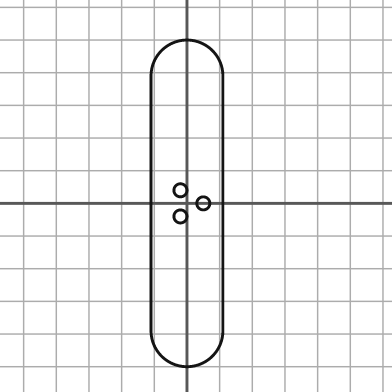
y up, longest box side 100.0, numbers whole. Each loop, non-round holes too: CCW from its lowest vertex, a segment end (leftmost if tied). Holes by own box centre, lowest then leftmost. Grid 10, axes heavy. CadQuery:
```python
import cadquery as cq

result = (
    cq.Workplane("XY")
    .moveTo(-11.0, -39.0)
    .threePointArc((0.0, -50.0), (11.0, -39.0))
    .lineTo(11.0, 39.0)
    .threePointArc((0.0, 50.0), (-11.0, 39.0))
    .close()
    .moveTo(-2.0, -4.0)
    .circle(2.0)
    .moveTo(5.0, 0.0)
    .circle(2.0)
    .moveTo(-2.0, 4.0)
    .circle(2.0)
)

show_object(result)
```